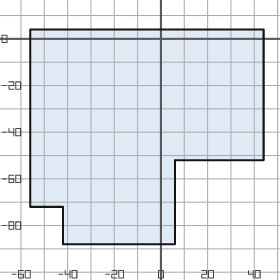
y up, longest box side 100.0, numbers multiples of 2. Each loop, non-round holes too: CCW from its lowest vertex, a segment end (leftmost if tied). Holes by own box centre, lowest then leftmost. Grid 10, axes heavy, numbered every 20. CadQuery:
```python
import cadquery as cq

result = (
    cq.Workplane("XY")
    .moveTo(-42.0, -88.0)
    .lineTo(6.0, -88.0)
    .lineTo(6.0, -52.0)
    .lineTo(44.0, -52.0)
    .lineTo(44.0, 4.0)
    .lineTo(-56.0, 4.0)
    .lineTo(-56.0, -72.0)
    .lineTo(-42.0, -72.0)
    .close()
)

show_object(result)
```